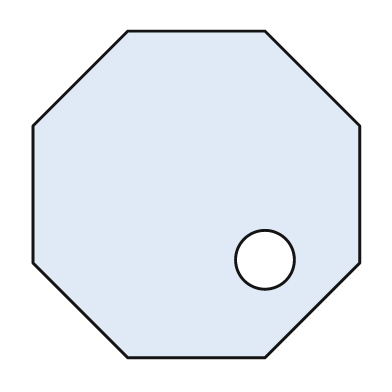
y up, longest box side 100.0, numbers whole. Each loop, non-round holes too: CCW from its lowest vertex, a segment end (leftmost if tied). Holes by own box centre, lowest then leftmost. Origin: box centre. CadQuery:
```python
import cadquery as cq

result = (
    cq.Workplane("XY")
    .moveTo(-21.0, -50.0)
    .lineTo(21.0, -50.0)
    .lineTo(50.0, -21.0)
    .lineTo(50.0, 21.0)
    .lineTo(21.0, 50.0)
    .lineTo(-21.0, 50.0)
    .lineTo(-50.0, 21.0)
    .lineTo(-50.0, -21.0)
    .close()
    .moveTo(21.0, -20.0)
    .circle(9.0)
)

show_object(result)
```